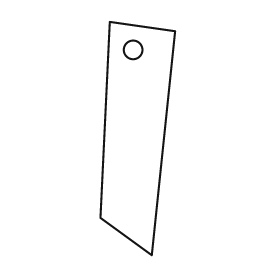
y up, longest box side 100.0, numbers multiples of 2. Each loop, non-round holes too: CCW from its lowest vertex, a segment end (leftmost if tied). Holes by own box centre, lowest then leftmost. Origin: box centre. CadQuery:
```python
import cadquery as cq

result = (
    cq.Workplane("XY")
    .moveTo(6.0, -50.0)
    .lineTo(16.0, 46.0)
    .lineTo(-12.0, 50.0)
    .lineTo(-16.0, -34.0)
    .close()
    .moveTo(-2.0, 38.0)
    .circle(4.0)
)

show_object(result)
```